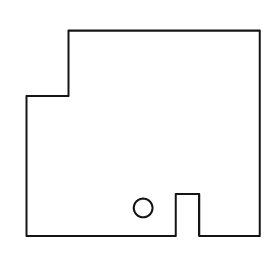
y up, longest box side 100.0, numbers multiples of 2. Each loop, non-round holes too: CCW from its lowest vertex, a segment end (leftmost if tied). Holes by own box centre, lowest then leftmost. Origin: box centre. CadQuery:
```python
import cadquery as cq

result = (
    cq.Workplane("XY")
    .moveTo(-50.0, -44.0)
    .lineTo(14.0, -44.0)
    .lineTo(14.0, -26.0)
    .lineTo(24.0, -26.0)
    .lineTo(24.0, -44.0)
    .lineTo(50.0, -44.0)
    .lineTo(50.0, 44.0)
    .lineTo(-32.0, 44.0)
    .lineTo(-32.0, 16.0)
    .lineTo(-50.0, 16.0)
    .close()
    .moveTo(0.0, -32.0)
    .circle(4.0)
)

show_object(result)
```